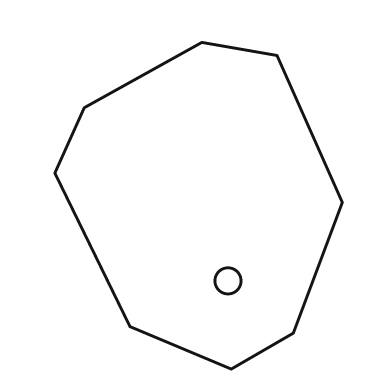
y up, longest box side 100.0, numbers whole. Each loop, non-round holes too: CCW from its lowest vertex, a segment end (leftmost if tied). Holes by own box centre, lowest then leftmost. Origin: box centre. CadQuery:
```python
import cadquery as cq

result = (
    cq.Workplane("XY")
    .moveTo(10.0, -50.0)
    .lineTo(29.0, -39.0)
    .lineTo(44.0, 1.0)
    .lineTo(24.0, 46.0)
    .lineTo(1.0, 50.0)
    .lineTo(-35.0, 30.0)
    .lineTo(-44.0, 10.0)
    .lineTo(-21.0, -37.0)
    .close()
    .moveTo(9.0, -23.0)
    .circle(4.0)
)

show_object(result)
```